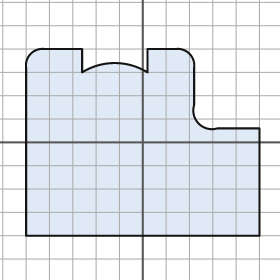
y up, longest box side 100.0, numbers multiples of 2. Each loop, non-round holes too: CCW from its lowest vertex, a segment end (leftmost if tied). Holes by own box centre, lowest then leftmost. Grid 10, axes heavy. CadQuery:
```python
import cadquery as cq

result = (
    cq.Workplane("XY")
    .moveTo(-50.0, -40.0)
    .lineTo(50.0, -40.0)
    .lineTo(50.0, 6.0)
    .lineTo(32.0, 6.0)
    .threePointArc((24.0, 8.0), (22.0, 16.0))
    .lineTo(22.0, 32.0)
    .threePointArc((20.0, 38.0), (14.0, 40.0))
    .lineTo(2.0, 40.0)
    .lineTo(2.0, 30.0)
    .threePointArc((-12.0, 34.0), (-26.0, 30.0))
    .lineTo(-26.0, 40.0)
    .lineTo(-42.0, 40.0)
    .threePointArc((-48.0, 38.0), (-50.0, 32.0))
    .close()
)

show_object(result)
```